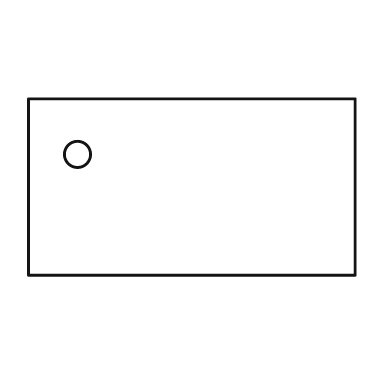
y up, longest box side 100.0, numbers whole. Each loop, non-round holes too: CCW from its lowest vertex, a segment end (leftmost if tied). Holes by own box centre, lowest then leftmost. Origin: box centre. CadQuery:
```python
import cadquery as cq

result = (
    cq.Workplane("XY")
    .moveTo(-50.0, -27.0)
    .lineTo(50.0, -27.0)
    .lineTo(50.0, 27.0)
    .lineTo(-50.0, 27.0)
    .close()
    .moveTo(-35.0, 10.0)
    .circle(4.0)
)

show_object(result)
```